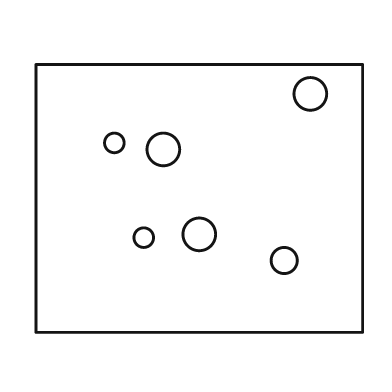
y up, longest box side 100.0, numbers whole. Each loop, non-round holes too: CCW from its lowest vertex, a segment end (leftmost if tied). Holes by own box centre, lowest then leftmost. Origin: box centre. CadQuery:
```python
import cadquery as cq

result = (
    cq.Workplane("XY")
    .moveTo(-50.0, -41.0)
    .lineTo(50.0, -41.0)
    .lineTo(50.0, 41.0)
    .lineTo(-50.0, 41.0)
    .close()
    .moveTo(26.0, -19.0)
    .circle(4.0)
    .moveTo(-17.0, -12.0)
    .circle(3.0)
    .moveTo(0.0, -11.0)
    .circle(5.0)
    .moveTo(-11.0, 15.0)
    .circle(5.0)
    .moveTo(-26.0, 17.0)
    .circle(3.0)
    .moveTo(34.0, 32.0)
    .circle(5.0)
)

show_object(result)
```